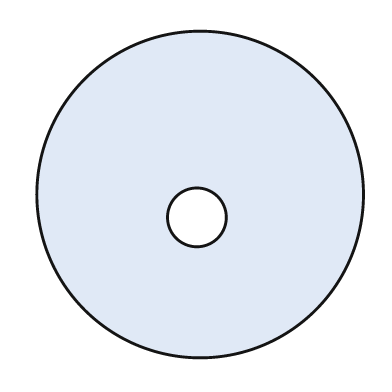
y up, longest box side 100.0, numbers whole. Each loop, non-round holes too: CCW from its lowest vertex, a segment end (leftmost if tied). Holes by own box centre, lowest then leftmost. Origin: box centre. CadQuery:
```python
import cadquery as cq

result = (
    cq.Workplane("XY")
    .moveTo(0.0, 0.0)
    .circle(50.0)
    .moveTo(-1.0, -7.0)
    .circle(9.0)
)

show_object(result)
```